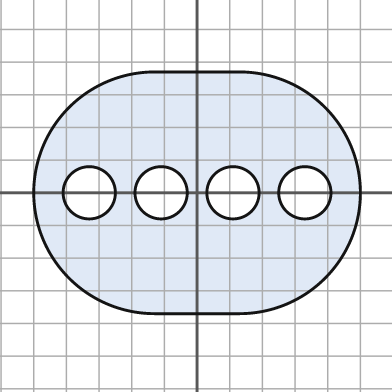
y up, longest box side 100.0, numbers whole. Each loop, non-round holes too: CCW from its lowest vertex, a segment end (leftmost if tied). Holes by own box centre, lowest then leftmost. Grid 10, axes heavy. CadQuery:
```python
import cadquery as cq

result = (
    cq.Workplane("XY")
    .moveTo(-13.0, -37.0)
    .lineTo(13.0, -37.0)
    .threePointArc((50.0, 0.0), (13.0, 37.0))
    .lineTo(-13.0, 37.0)
    .threePointArc((-50.0, 0.0), (-13.0, -37.0))
    .close()
    .moveTo(-33.0, 0.0)
    .circle(8.0)
    .moveTo(-11.0, 0.0)
    .circle(8.0)
    .moveTo(11.0, 0.0)
    .circle(8.0)
    .moveTo(33.0, 0.0)
    .circle(8.0)
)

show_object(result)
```